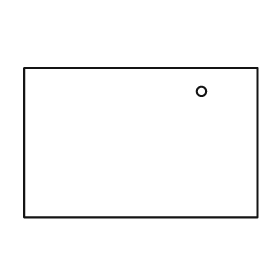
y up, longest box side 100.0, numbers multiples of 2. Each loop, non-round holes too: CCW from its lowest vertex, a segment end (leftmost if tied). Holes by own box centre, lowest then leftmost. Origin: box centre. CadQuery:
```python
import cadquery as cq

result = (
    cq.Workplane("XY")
    .moveTo(-50.0, -32.0)
    .lineTo(50.0, -32.0)
    .lineTo(50.0, 32.0)
    .lineTo(-50.0, 32.0)
    .close()
    .moveTo(26.0, 22.0)
    .circle(2.0)
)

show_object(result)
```